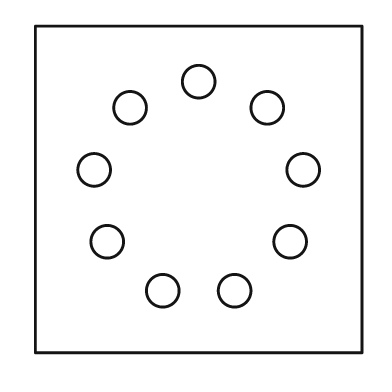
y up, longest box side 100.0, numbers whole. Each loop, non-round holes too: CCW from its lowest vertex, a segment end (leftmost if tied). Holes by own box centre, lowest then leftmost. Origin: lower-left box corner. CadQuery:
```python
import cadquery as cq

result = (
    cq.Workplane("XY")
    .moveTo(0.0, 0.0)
    .lineTo(100.0, 0.0)
    .lineTo(100.0, 100.0)
    .lineTo(0.0, 100.0)
    .close()
    .moveTo(39.0, 19.0)
    .circle(5.0)
    .moveTo(61.0, 19.0)
    .circle(5.0)
    .moveTo(22.0, 34.0)
    .circle(5.0)
    .moveTo(78.0, 34.0)
    .circle(5.0)
    .moveTo(18.0, 56.0)
    .circle(5.0)
    .moveTo(82.0, 56.0)
    .circle(5.0)
    .moveTo(29.0, 75.0)
    .circle(5.0)
    .moveTo(71.0, 75.0)
    .circle(5.0)
    .moveTo(50.0, 83.0)
    .circle(5.0)
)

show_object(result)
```